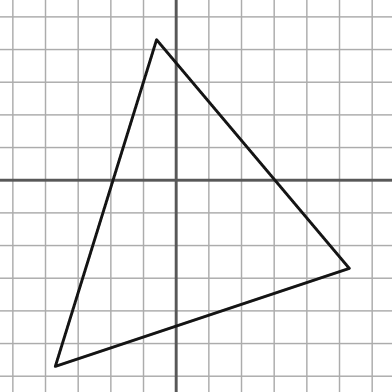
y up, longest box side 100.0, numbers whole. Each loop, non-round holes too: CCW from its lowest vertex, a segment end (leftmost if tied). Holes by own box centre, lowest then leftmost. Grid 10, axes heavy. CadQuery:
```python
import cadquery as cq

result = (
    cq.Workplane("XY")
    .moveTo(-37.0, -57.0)
    .lineTo(53.0, -27.0)
    .lineTo(-6.0, 43.0)
    .close()
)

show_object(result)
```